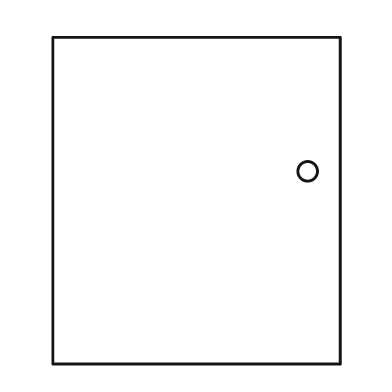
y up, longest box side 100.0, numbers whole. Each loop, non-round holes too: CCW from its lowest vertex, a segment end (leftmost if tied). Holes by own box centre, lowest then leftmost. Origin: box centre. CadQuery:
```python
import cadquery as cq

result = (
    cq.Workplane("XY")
    .moveTo(-44.0, -50.0)
    .lineTo(44.0, -50.0)
    .lineTo(44.0, 50.0)
    .lineTo(-44.0, 50.0)
    .close()
    .moveTo(34.0, 9.0)
    .circle(3.0)
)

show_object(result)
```